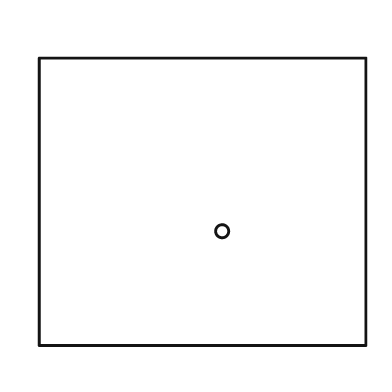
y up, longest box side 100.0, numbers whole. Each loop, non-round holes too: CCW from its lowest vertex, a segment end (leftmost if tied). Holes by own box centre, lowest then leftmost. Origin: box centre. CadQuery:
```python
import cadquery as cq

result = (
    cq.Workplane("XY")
    .moveTo(-50.0, -44.0)
    .lineTo(50.0, -44.0)
    .lineTo(50.0, 44.0)
    .lineTo(-50.0, 44.0)
    .close()
    .moveTo(6.0, -9.0)
    .circle(2.0)
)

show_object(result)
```